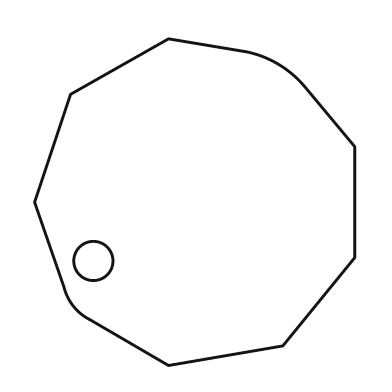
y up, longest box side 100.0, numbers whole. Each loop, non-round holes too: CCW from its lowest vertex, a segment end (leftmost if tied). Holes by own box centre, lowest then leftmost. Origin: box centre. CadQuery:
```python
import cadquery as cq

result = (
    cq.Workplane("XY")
    .moveTo(-8.0, -50.0)
    .lineTo(27.0, -44.0)
    .lineTo(49.0, -17.0)
    .lineTo(49.0, 17.0)
    .lineTo(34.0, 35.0)
    .threePointArc((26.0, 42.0), (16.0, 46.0))
    .lineTo(-8.0, 50.0)
    .lineTo(-38.0, 33.0)
    .lineTo(-49.0, 0.0)
    .lineTo(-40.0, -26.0)
    .threePointArc((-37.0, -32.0), (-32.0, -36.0))
    .close()
    .moveTo(-31.0, -18.0)
    .circle(6.0)
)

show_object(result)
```